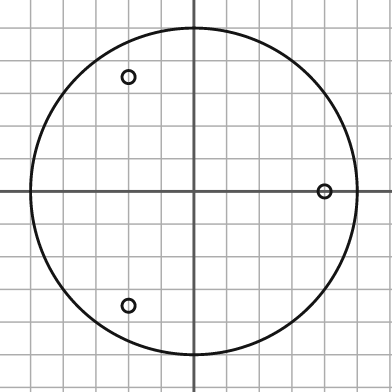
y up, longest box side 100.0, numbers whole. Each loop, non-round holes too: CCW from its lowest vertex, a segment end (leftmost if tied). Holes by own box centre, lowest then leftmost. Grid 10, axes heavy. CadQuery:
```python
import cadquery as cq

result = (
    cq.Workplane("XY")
    .moveTo(0.0, 0.0)
    .circle(50.0)
    .moveTo(-20.0, -35.0)
    .circle(2.0)
    .moveTo(40.0, 0.0)
    .circle(2.0)
    .moveTo(-20.0, 35.0)
    .circle(2.0)
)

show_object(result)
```